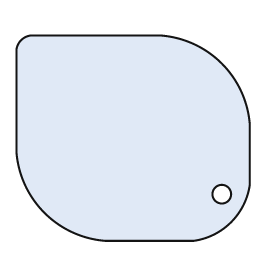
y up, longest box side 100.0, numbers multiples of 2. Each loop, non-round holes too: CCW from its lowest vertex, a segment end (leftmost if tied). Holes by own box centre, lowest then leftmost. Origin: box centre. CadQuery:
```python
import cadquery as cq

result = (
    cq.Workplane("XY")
    .moveTo(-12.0, -44.0)
    .lineTo(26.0, -44.0)
    .threePointArc((42.0, -36.0), (50.0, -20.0))
    .lineTo(50.0, 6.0)
    .threePointArc((38.0, 32.0), (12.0, 44.0))
    .lineTo(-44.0, 44.0)
    .threePointArc((-48.0, 42.0), (-50.0, 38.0))
    .lineTo(-50.0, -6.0)
    .threePointArc((-38.0, -32.0), (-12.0, -44.0))
    .close()
    .moveTo(38.0, -24.0)
    .circle(4.0)
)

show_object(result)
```